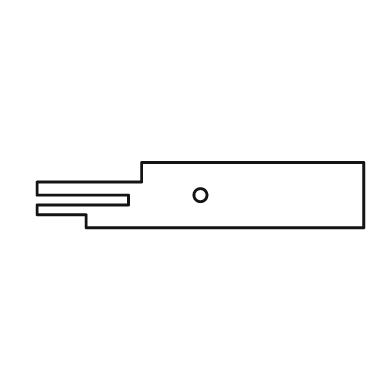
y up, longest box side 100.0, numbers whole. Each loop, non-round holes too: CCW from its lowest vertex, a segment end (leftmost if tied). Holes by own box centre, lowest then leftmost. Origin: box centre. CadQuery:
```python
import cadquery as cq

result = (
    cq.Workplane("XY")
    .moveTo(-35.0, -10.0)
    .lineTo(50.0, -10.0)
    .lineTo(50.0, 10.0)
    .lineTo(-18.0, 10.0)
    .lineTo(-18.0, 4.0)
    .lineTo(-50.0, 4.0)
    .lineTo(-50.0, 0.0)
    .lineTo(-22.0, 0.0)
    .lineTo(-22.0, -3.0)
    .lineTo(-50.0, -3.0)
    .lineTo(-50.0, -6.0)
    .lineTo(-35.0, -6.0)
    .close()
    .moveTo(0.0, 0.0)
    .circle(2.0)
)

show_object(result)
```